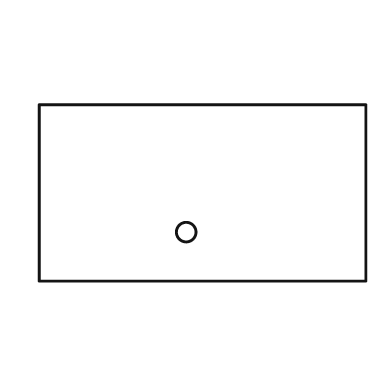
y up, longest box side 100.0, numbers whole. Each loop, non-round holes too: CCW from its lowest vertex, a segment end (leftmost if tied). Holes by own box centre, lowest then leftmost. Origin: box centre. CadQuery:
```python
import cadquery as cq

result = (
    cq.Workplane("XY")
    .moveTo(-50.0, -27.0)
    .lineTo(50.0, -27.0)
    .lineTo(50.0, 27.0)
    .lineTo(-50.0, 27.0)
    .close()
    .moveTo(-5.0, -12.0)
    .circle(3.0)
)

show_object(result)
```